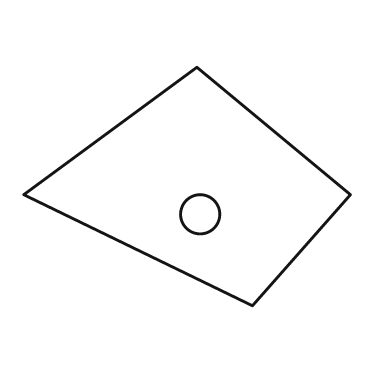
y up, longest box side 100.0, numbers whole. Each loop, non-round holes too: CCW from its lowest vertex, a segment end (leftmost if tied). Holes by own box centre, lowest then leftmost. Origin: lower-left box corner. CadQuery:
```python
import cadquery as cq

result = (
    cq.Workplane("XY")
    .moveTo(70.0, 0.0)
    .lineTo(100.0, 34.0)
    .lineTo(53.0, 73.0)
    .lineTo(0.0, 34.0)
    .close()
    .moveTo(54.0, 28.0)
    .circle(6.0)
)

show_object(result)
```